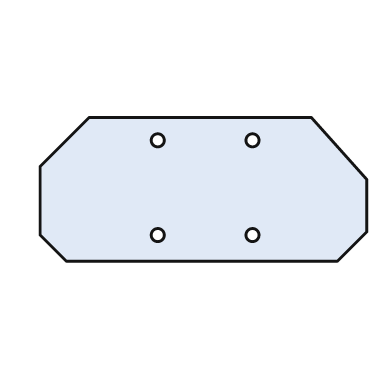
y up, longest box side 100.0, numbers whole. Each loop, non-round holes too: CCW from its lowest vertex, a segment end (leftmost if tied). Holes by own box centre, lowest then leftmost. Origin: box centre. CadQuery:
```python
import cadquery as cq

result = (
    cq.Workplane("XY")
    .moveTo(-42.0, -22.0)
    .lineTo(41.0, -22.0)
    .lineTo(50.0, -13.0)
    .lineTo(50.0, 3.0)
    .lineTo(33.0, 22.0)
    .lineTo(-35.0, 22.0)
    .lineTo(-50.0, 7.0)
    .lineTo(-50.0, -14.0)
    .close()
    .moveTo(-14.0, -14.0)
    .circle(2.0)
    .moveTo(15.0, -14.0)
    .circle(2.0)
    .moveTo(-14.0, 15.0)
    .circle(2.0)
    .moveTo(15.0, 15.0)
    .circle(2.0)
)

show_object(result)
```